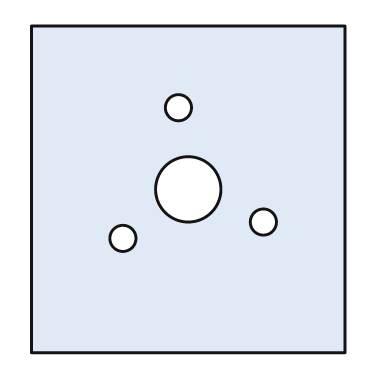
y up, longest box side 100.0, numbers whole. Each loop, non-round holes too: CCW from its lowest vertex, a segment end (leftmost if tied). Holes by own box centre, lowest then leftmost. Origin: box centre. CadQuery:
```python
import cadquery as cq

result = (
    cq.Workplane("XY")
    .moveTo(-48.0, -50.0)
    .lineTo(48.0, -50.0)
    .lineTo(48.0, 50.0)
    .lineTo(-48.0, 50.0)
    .close()
    .moveTo(-20.0, -15.0)
    .circle(4.0)
    .moveTo(23.0, -10.0)
    .circle(4.0)
    .moveTo(0.0, 0.0)
    .circle(10.0)
    .moveTo(-3.0, 25.0)
    .circle(4.0)
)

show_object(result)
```